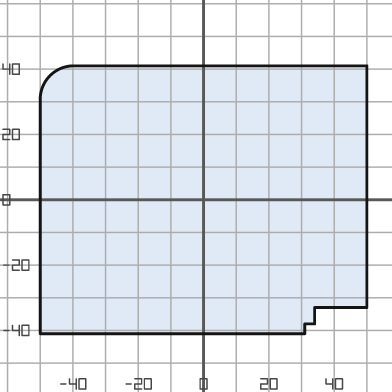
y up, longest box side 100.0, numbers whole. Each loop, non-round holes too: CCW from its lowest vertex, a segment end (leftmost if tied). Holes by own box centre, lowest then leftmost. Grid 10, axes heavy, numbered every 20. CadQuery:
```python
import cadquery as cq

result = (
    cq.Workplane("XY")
    .moveTo(-50.0, -41.0)
    .lineTo(31.0, -41.0)
    .lineTo(31.0, -38.0)
    .lineTo(34.0, -38.0)
    .lineTo(34.0, -33.0)
    .lineTo(50.0, -33.0)
    .lineTo(50.0, 41.0)
    .lineTo(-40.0, 41.0)
    .threePointArc((-47.0, 38.0), (-50.0, 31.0))
    .close()
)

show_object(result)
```